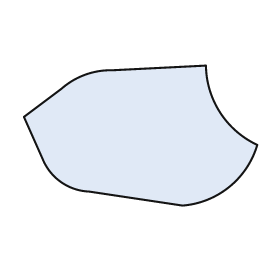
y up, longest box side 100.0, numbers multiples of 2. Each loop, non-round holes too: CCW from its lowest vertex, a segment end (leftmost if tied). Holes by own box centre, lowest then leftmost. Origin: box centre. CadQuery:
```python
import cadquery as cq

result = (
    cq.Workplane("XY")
    .moveTo(18.0, -30.0)
    .threePointArc((38.0, -22.0), (50.0, -4.0))
    .threePointArc((34.0, 10.0), (28.0, 30.0))
    .lineTo(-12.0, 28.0)
    .threePointArc((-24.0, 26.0), (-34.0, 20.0))
    .lineTo(-50.0, 8.0)
    .lineTo(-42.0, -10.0)
    .threePointArc((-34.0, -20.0), (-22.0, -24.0))
    .close()
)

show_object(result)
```